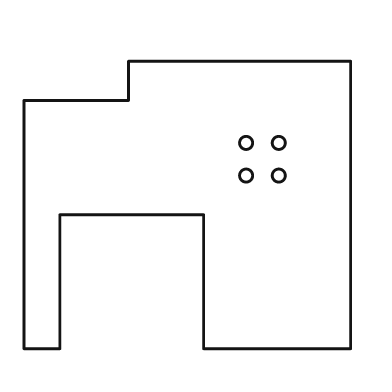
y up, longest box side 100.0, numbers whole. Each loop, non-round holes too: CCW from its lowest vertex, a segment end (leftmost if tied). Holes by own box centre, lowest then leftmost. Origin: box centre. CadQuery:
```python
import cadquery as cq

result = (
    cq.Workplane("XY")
    .moveTo(-50.0, -44.0)
    .lineTo(-39.0, -44.0)
    .lineTo(-39.0, -3.0)
    .lineTo(5.0, -3.0)
    .lineTo(5.0, -44.0)
    .lineTo(50.0, -44.0)
    .lineTo(50.0, 44.0)
    .lineTo(-18.0, 44.0)
    .lineTo(-18.0, 32.0)
    .lineTo(-50.0, 32.0)
    .close()
    .moveTo(18.0, 9.0)
    .circle(2.0)
    .moveTo(28.0, 9.0)
    .circle(2.0)
    .moveTo(18.0, 19.0)
    .circle(2.0)
    .moveTo(28.0, 19.0)
    .circle(2.0)
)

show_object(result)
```